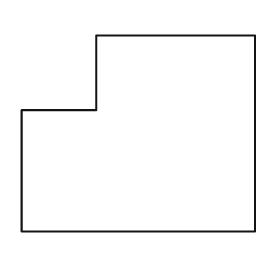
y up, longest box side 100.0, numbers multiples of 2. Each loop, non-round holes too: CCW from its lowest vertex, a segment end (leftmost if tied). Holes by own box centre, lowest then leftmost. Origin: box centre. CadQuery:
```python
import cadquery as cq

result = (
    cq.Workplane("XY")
    .moveTo(-50.0, -42.0)
    .lineTo(50.0, -42.0)
    .lineTo(50.0, 42.0)
    .lineTo(-18.0, 42.0)
    .lineTo(-18.0, 10.0)
    .lineTo(-50.0, 10.0)
    .close()
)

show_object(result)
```